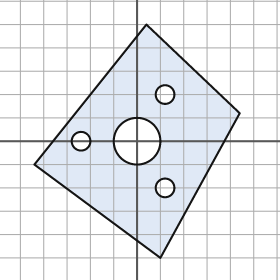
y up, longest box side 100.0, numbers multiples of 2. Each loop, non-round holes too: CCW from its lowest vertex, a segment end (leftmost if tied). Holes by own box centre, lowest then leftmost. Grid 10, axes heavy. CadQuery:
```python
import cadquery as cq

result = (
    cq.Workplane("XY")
    .moveTo(10.0, -50.0)
    .lineTo(44.0, 12.0)
    .lineTo(4.0, 50.0)
    .lineTo(-44.0, -10.0)
    .close()
    .moveTo(12.0, -20.0)
    .circle(4.0)
    .moveTo(-24.0, 0.0)
    .circle(4.0)
    .moveTo(0.0, 0.0)
    .circle(10.0)
    .moveTo(12.0, 20.0)
    .circle(4.0)
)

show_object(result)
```